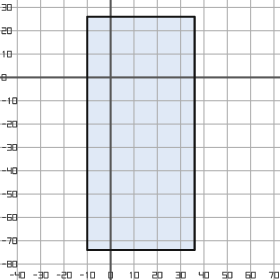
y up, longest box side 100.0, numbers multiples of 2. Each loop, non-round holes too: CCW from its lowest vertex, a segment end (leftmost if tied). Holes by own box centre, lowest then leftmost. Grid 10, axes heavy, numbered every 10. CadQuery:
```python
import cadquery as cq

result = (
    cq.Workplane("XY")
    .moveTo(-10.0, -74.0)
    .lineTo(36.0, -74.0)
    .lineTo(36.0, 26.0)
    .lineTo(-10.0, 26.0)
    .close()
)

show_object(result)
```